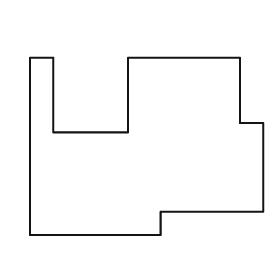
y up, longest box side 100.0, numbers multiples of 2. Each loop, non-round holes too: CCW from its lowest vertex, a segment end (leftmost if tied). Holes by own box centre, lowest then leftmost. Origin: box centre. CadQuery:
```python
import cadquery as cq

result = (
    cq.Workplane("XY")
    .moveTo(-50.0, -38.0)
    .lineTo(6.0, -38.0)
    .lineTo(6.0, -28.0)
    .lineTo(50.0, -28.0)
    .lineTo(50.0, 10.0)
    .lineTo(40.0, 10.0)
    .lineTo(40.0, 38.0)
    .lineTo(-8.0, 38.0)
    .lineTo(-8.0, 6.0)
    .lineTo(-40.0, 6.0)
    .lineTo(-40.0, 38.0)
    .lineTo(-50.0, 38.0)
    .close()
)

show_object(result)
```